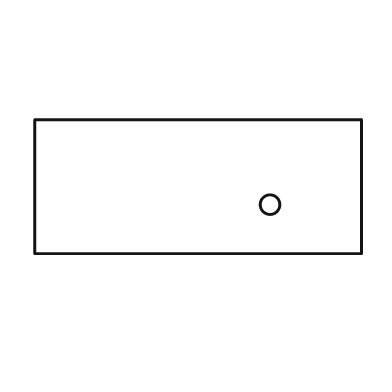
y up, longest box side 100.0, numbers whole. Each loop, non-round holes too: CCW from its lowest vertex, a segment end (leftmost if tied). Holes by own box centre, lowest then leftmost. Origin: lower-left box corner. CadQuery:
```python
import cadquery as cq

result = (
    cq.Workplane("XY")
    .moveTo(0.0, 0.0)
    .lineTo(100.0, 0.0)
    .lineTo(100.0, 41.0)
    .lineTo(0.0, 41.0)
    .close()
    .moveTo(72.0, 15.0)
    .circle(3.0)
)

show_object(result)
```